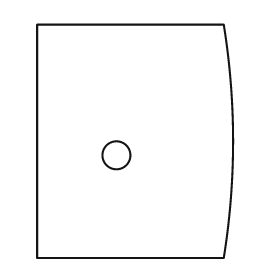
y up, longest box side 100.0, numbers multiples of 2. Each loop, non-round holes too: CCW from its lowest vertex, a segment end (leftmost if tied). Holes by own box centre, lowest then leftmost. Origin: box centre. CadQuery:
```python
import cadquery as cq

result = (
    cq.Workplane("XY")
    .moveTo(-42.0, -50.0)
    .lineTo(38.0, -50.0)
    .threePointArc((42.0, 0.0), (38.0, 50.0))
    .lineTo(-42.0, 50.0)
    .close()
    .moveTo(-8.0, -6.0)
    .circle(6.0)
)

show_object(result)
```